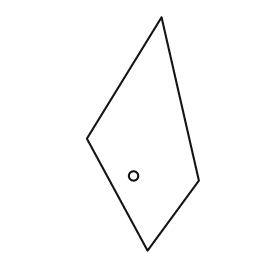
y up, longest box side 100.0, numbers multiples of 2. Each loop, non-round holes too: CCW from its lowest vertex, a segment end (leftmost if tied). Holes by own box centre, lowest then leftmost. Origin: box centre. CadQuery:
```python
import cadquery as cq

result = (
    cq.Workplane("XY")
    .moveTo(2.0, -50.0)
    .lineTo(24.0, -20.0)
    .lineTo(8.0, 50.0)
    .lineTo(-24.0, -2.0)
    .close()
    .moveTo(-4.0, -18.0)
    .circle(2.0)
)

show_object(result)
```